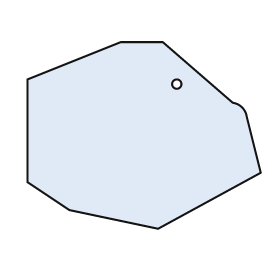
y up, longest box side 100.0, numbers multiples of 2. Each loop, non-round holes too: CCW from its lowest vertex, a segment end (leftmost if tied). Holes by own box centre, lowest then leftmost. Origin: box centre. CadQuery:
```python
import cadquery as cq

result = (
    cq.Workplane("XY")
    .moveTo(6.0, -40.0)
    .lineTo(50.0, -16.0)
    .lineTo(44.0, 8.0)
    .threePointArc((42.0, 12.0), (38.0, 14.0))
    .lineTo(8.0, 40.0)
    .lineTo(-10.0, 40.0)
    .lineTo(-50.0, 24.0)
    .lineTo(-50.0, -20.0)
    .lineTo(-32.0, -32.0)
    .close()
    .moveTo(14.0, 22.0)
    .circle(2.0)
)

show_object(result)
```